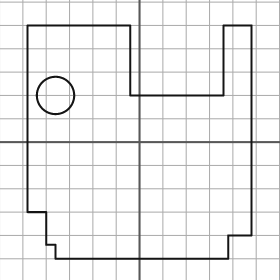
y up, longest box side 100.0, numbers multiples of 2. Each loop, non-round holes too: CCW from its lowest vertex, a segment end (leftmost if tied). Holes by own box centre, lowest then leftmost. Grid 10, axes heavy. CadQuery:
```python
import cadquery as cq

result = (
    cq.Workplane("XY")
    .moveTo(-36.0, -50.0)
    .lineTo(38.0, -50.0)
    .lineTo(38.0, -40.0)
    .lineTo(48.0, -40.0)
    .lineTo(48.0, 50.0)
    .lineTo(36.0, 50.0)
    .lineTo(36.0, 20.0)
    .lineTo(-4.0, 20.0)
    .lineTo(-4.0, 50.0)
    .lineTo(-48.0, 50.0)
    .lineTo(-48.0, -30.0)
    .lineTo(-40.0, -30.0)
    .lineTo(-40.0, -44.0)
    .lineTo(-36.0, -44.0)
    .close()
    .moveTo(-36.0, 20.0)
    .circle(8.0)
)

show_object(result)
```